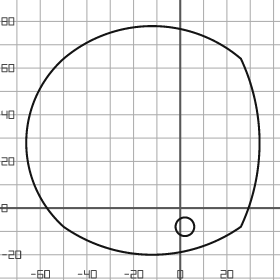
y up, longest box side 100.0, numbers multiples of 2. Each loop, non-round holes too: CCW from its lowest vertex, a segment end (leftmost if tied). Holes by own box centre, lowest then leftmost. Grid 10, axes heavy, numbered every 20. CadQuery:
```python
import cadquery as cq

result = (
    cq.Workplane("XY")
    .moveTo(-50.0, -8.0)
    .threePointArc((-12.0, -20.0), (26.0, -8.0))
    .threePointArc((34.0, 28.0), (26.0, 64.0))
    .threePointArc((-12.0, 78.0), (-50.0, 64.0))
    .threePointArc((-66.0, 28.0), (-50.0, -8.0))
    .close()
    .moveTo(2.0, -8.0)
    .circle(4.0)
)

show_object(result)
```